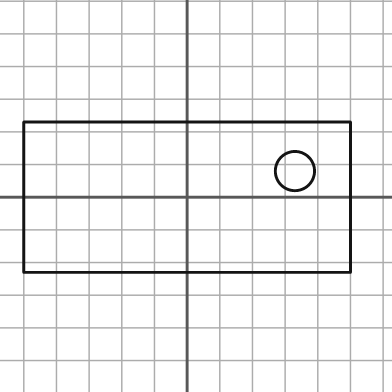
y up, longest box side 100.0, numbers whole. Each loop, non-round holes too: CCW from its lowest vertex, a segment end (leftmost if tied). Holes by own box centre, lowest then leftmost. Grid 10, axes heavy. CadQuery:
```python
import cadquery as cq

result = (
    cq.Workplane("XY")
    .moveTo(-50.0, -23.0)
    .lineTo(50.0, -23.0)
    .lineTo(50.0, 23.0)
    .lineTo(-50.0, 23.0)
    .close()
    .moveTo(33.0, 8.0)
    .circle(6.0)
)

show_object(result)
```